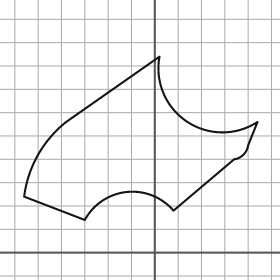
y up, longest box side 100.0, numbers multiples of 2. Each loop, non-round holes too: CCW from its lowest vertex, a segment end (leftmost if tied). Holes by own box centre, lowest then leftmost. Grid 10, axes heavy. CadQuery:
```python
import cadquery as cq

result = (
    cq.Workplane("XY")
    .moveTo(-30.0, 14.0)
    .threePointArc((-12.0, 26.0), (8.0, 18.0))
    .lineTo(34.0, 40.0)
    .threePointArc((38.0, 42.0), (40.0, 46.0))
    .lineTo(44.0, 56.0)
    .threePointArc((14.0, 56.0), (2.0, 84.0))
    .lineTo(-38.0, 56.0)
    .threePointArc((-50.0, 42.0), (-56.0, 24.0))
    .close()
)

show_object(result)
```